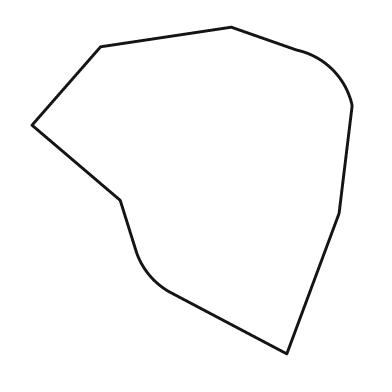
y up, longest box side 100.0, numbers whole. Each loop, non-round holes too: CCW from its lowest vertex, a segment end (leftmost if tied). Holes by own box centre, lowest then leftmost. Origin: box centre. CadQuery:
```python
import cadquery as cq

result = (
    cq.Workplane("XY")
    .moveTo(29.0, -50.0)
    .lineTo(45.0, -7.0)
    .lineTo(49.0, 26.0)
    .threePointArc((43.0, 37.0), (32.0, 43.0))
    .lineTo(12.0, 50.0)
    .lineTo(-28.0, 44.0)
    .lineTo(-49.0, 20.0)
    .lineTo(-22.0, -3.0)
    .lineTo(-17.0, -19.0)
    .threePointArc((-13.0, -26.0), (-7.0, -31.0))
    .close()
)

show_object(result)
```